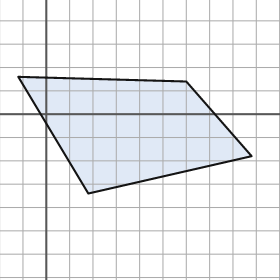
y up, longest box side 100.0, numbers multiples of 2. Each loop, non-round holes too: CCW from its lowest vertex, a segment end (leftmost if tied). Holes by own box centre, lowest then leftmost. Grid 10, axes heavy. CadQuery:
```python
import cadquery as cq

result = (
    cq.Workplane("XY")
    .moveTo(18.0, -34.0)
    .lineTo(88.0, -18.0)
    .lineTo(60.0, 14.0)
    .lineTo(-12.0, 16.0)
    .close()
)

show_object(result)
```